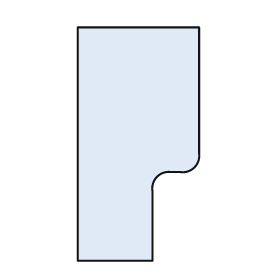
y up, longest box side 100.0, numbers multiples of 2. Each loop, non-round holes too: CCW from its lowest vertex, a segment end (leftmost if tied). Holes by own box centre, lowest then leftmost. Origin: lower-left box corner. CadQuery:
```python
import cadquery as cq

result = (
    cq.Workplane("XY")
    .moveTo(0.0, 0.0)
    .lineTo(32.0, 0.0)
    .lineTo(32.0, 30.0)
    .threePointArc((34.0, 36.0), (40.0, 38.0))
    .lineTo(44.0, 38.0)
    .threePointArc((50.0, 40.0), (52.0, 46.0))
    .lineTo(52.0, 100.0)
    .lineTo(0.0, 100.0)
    .close()
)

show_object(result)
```